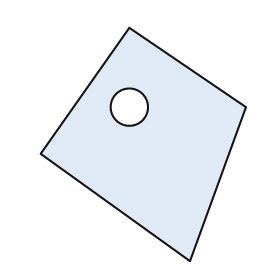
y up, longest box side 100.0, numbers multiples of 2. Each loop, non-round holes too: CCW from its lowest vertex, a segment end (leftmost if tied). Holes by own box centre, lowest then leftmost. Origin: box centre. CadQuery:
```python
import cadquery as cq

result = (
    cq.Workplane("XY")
    .moveTo(20.0, -50.0)
    .lineTo(44.0, 16.0)
    .lineTo(-6.0, 50.0)
    .lineTo(-44.0, -4.0)
    .close()
    .moveTo(-6.0, 16.0)
    .circle(8.0)
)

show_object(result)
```